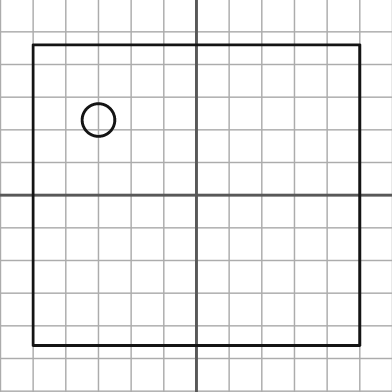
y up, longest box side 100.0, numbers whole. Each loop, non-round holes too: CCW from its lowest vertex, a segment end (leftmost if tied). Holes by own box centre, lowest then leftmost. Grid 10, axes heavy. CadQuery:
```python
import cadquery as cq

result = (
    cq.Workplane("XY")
    .moveTo(-50.0, -46.0)
    .lineTo(50.0, -46.0)
    .lineTo(50.0, 46.0)
    .lineTo(-50.0, 46.0)
    .close()
    .moveTo(-30.0, 23.0)
    .circle(5.0)
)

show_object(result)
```